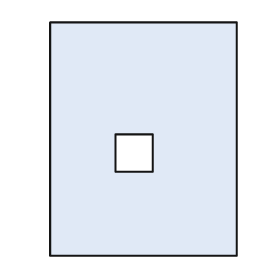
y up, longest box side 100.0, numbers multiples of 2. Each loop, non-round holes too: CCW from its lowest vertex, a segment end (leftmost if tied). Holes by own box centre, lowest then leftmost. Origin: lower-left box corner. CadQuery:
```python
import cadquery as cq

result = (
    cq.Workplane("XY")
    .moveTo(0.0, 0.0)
    .lineTo(80.0, 0.0)
    .lineTo(80.0, 100.0)
    .lineTo(0.0, 100.0)
    .close()
    .moveTo(28.0, 36.0)
    .lineTo(44.0, 36.0)
    .lineTo(44.0, 52.0)
    .lineTo(28.0, 52.0)
    .close()
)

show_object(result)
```